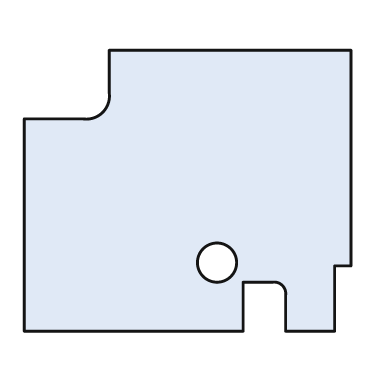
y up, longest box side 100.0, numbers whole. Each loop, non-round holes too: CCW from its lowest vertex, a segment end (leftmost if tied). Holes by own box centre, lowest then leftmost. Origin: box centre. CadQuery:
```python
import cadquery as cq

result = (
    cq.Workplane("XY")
    .moveTo(-50.0, -43.0)
    .lineTo(17.0, -43.0)
    .lineTo(17.0, -28.0)
    .lineTo(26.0, -28.0)
    .threePointArc((29.0, -29.0), (30.0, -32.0))
    .lineTo(30.0, -43.0)
    .lineTo(45.0, -43.0)
    .lineTo(45.0, -23.0)
    .lineTo(50.0, -23.0)
    .lineTo(50.0, 43.0)
    .lineTo(-24.0, 43.0)
    .lineTo(-24.0, 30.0)
    .threePointArc((-26.0, 24.0), (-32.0, 22.0))
    .lineTo(-50.0, 22.0)
    .close()
    .moveTo(9.0, -22.0)
    .circle(6.0)
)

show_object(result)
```